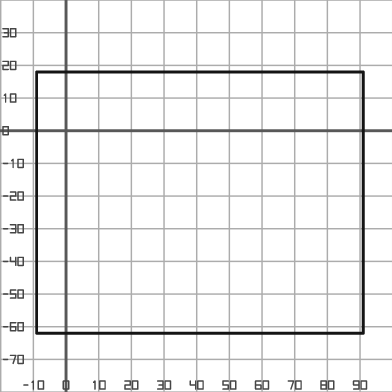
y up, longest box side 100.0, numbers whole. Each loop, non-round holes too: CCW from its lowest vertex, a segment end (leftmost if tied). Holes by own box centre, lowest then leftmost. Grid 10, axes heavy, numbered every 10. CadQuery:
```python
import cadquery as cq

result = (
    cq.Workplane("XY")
    .moveTo(-9.0, -62.0)
    .lineTo(91.0, -62.0)
    .lineTo(91.0, 18.0)
    .lineTo(-9.0, 18.0)
    .close()
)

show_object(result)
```